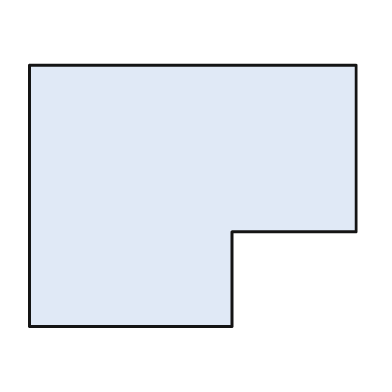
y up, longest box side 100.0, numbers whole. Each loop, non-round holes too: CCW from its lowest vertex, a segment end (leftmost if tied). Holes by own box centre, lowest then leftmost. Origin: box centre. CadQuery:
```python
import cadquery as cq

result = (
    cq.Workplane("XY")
    .moveTo(-50.0, -40.0)
    .lineTo(12.0, -40.0)
    .lineTo(12.0, -11.0)
    .lineTo(50.0, -11.0)
    .lineTo(50.0, 40.0)
    .lineTo(-50.0, 40.0)
    .close()
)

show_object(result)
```